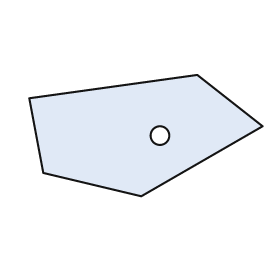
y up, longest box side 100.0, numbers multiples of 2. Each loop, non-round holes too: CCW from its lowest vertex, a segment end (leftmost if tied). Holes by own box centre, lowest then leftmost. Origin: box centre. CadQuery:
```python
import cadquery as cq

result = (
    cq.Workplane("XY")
    .moveTo(-2.0, -26.0)
    .lineTo(50.0, 4.0)
    .lineTo(22.0, 26.0)
    .lineTo(-50.0, 16.0)
    .lineTo(-44.0, -16.0)
    .close()
    .moveTo(6.0, 0.0)
    .circle(4.0)
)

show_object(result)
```